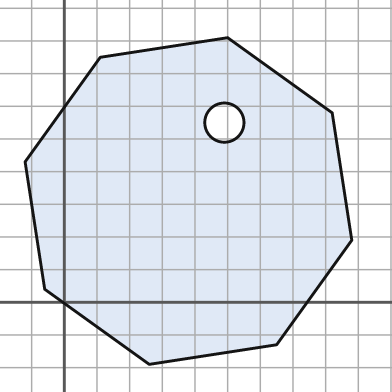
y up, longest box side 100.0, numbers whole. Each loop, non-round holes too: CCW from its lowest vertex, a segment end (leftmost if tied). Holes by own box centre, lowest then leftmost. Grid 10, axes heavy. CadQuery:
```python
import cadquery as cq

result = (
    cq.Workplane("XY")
    .moveTo(26.0, -19.0)
    .lineTo(65.0, -13.0)
    .lineTo(88.0, 19.0)
    .lineTo(82.0, 58.0)
    .lineTo(50.0, 81.0)
    .lineTo(11.0, 75.0)
    .lineTo(-12.0, 43.0)
    .lineTo(-6.0, 4.0)
    .close()
    .moveTo(49.0, 55.0)
    .circle(6.0)
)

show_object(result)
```